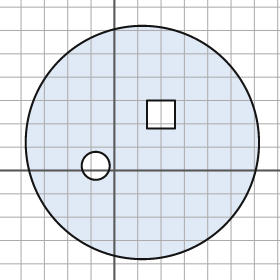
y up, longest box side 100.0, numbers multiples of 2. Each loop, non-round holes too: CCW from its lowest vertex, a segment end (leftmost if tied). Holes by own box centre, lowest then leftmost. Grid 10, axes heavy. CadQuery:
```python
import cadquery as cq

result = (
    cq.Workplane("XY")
    .moveTo(12.0, 12.0)
    .circle(50.0)
    .moveTo(-8.0, 2.0)
    .circle(6.0)
    .moveTo(14.0, 18.0)
    .lineTo(26.0, 18.0)
    .lineTo(26.0, 30.0)
    .lineTo(14.0, 30.0)
    .close()
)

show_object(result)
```